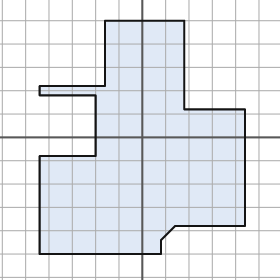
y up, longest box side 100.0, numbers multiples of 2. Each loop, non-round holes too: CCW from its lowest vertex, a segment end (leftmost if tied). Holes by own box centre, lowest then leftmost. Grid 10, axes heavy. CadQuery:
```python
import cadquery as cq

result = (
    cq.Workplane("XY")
    .moveTo(-44.0, -50.0)
    .lineTo(8.0, -50.0)
    .lineTo(8.0, -44.0)
    .lineTo(14.0, -38.0)
    .lineTo(44.0, -38.0)
    .lineTo(44.0, 12.0)
    .lineTo(18.0, 12.0)
    .lineTo(18.0, 50.0)
    .lineTo(-16.0, 50.0)
    .lineTo(-16.0, 22.0)
    .lineTo(-44.0, 22.0)
    .lineTo(-44.0, 18.0)
    .lineTo(-20.0, 18.0)
    .lineTo(-20.0, -8.0)
    .lineTo(-44.0, -8.0)
    .close()
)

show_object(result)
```